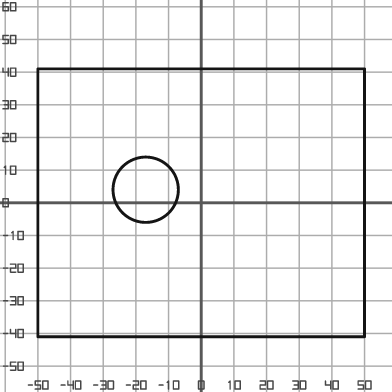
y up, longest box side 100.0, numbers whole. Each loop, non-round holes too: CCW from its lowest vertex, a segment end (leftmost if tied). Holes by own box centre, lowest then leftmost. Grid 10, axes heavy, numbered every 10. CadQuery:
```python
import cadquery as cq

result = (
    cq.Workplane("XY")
    .moveTo(-50.0, -41.0)
    .lineTo(50.0, -41.0)
    .lineTo(50.0, 41.0)
    .lineTo(-50.0, 41.0)
    .close()
    .moveTo(-17.0, 4.0)
    .circle(10.0)
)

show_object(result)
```